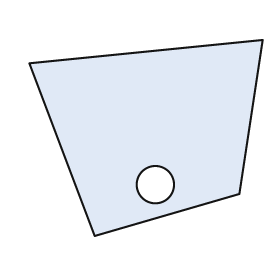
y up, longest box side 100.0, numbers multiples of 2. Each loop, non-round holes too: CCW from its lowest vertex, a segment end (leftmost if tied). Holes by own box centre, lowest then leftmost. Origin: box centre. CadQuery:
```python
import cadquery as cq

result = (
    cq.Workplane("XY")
    .moveTo(-22.0, -42.0)
    .lineTo(40.0, -24.0)
    .lineTo(50.0, 42.0)
    .lineTo(-50.0, 32.0)
    .close()
    .moveTo(4.0, -20.0)
    .circle(8.0)
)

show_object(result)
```